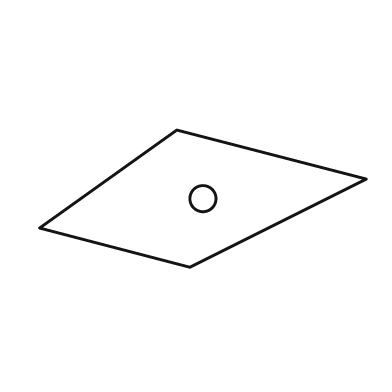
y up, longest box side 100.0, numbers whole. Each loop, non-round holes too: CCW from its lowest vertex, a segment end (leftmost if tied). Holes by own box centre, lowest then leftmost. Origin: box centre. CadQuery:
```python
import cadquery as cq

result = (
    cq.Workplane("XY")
    .moveTo(-4.0, -21.0)
    .lineTo(50.0, 6.0)
    .lineTo(-8.0, 21.0)
    .lineTo(-50.0, -9.0)
    .close()
    .moveTo(0.0, 0.0)
    .circle(4.0)
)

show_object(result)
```